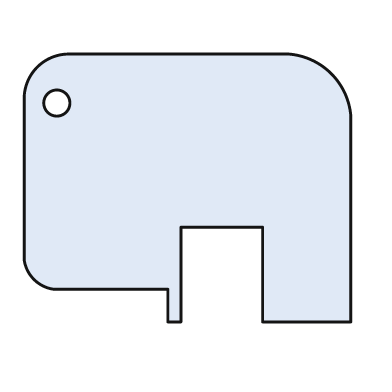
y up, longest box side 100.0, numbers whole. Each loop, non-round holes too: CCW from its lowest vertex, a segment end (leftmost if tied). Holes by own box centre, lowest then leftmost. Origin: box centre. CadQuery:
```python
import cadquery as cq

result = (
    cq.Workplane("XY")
    .moveTo(-6.0, -41.0)
    .lineTo(-2.0, -41.0)
    .lineTo(-2.0, -12.0)
    .lineTo(23.0, -12.0)
    .lineTo(23.0, -41.0)
    .lineTo(50.0, -41.0)
    .lineTo(50.0, 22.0)
    .threePointArc((44.0, 35.0), (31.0, 41.0))
    .lineTo(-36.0, 41.0)
    .threePointArc((-46.0, 37.0), (-50.0, 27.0))
    .lineTo(-50.0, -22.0)
    .threePointArc((-47.0, -28.0), (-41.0, -31.0))
    .lineTo(-6.0, -31.0)
    .close()
    .moveTo(-40.0, 26.0)
    .circle(4.0)
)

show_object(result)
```